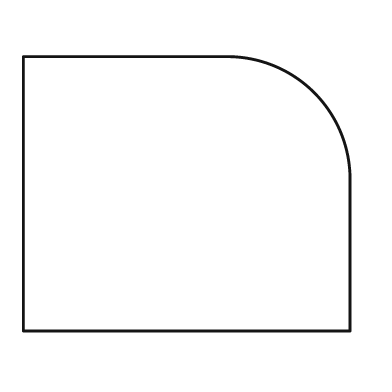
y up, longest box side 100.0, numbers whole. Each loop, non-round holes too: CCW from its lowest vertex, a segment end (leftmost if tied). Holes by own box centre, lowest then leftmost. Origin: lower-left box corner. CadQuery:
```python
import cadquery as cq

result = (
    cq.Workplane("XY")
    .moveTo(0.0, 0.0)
    .lineTo(100.0, 0.0)
    .lineTo(100.0, 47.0)
    .threePointArc((89.0, 73.0), (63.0, 84.0))
    .lineTo(0.0, 84.0)
    .close()
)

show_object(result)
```